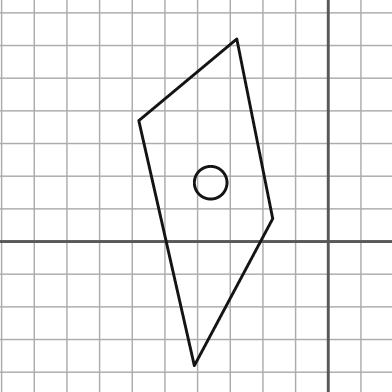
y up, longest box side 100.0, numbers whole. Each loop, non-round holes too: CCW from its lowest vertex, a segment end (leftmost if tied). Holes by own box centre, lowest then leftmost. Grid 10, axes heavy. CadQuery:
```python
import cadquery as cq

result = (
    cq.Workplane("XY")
    .moveTo(-41.0, -38.0)
    .lineTo(-17.0, 7.0)
    .lineTo(-28.0, 62.0)
    .lineTo(-58.0, 37.0)
    .close()
    .moveTo(-36.0, 18.0)
    .circle(5.0)
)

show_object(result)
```